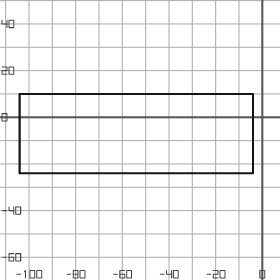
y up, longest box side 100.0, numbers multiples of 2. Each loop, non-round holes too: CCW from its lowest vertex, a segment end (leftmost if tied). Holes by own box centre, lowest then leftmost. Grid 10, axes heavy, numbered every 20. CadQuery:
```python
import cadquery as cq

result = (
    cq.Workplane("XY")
    .moveTo(-104.0, -24.0)
    .lineTo(-4.0, -24.0)
    .lineTo(-4.0, 10.0)
    .lineTo(-104.0, 10.0)
    .close()
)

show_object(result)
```